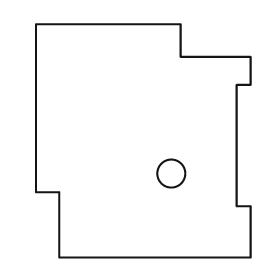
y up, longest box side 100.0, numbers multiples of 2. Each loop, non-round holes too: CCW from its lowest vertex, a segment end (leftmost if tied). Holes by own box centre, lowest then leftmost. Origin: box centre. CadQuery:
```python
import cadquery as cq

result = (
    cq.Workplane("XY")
    .moveTo(-36.0, -50.0)
    .lineTo(46.0, -50.0)
    .lineTo(46.0, -28.0)
    .lineTo(40.0, -28.0)
    .lineTo(40.0, 24.0)
    .lineTo(46.0, 24.0)
    .lineTo(46.0, 36.0)
    .lineTo(16.0, 36.0)
    .lineTo(16.0, 50.0)
    .lineTo(-46.0, 50.0)
    .lineTo(-46.0, -22.0)
    .lineTo(-36.0, -22.0)
    .close()
    .moveTo(12.0, -14.0)
    .circle(6.0)
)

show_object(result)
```